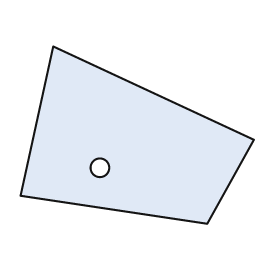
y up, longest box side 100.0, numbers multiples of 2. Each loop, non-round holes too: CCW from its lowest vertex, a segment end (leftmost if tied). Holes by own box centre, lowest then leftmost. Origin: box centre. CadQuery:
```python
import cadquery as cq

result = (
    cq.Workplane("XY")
    .moveTo(30.0, -38.0)
    .lineTo(50.0, -2.0)
    .lineTo(-36.0, 38.0)
    .lineTo(-50.0, -26.0)
    .close()
    .moveTo(-16.0, -14.0)
    .circle(4.0)
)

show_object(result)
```